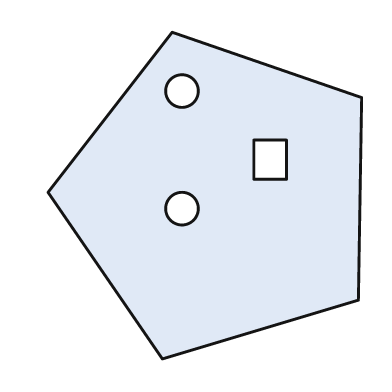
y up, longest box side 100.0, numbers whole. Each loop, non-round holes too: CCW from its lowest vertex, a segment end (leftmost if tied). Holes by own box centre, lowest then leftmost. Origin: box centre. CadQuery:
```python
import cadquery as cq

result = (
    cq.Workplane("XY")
    .moveTo(-13.0, -50.0)
    .lineTo(47.0, -32.0)
    .lineTo(48.0, 30.0)
    .lineTo(-10.0, 50.0)
    .lineTo(-48.0, 1.0)
    .close()
    .moveTo(-7.0, -4.0)
    .circle(5.0)
    .moveTo(15.0, 5.0)
    .lineTo(25.0, 5.0)
    .lineTo(25.0, 17.0)
    .lineTo(15.0, 17.0)
    .close()
    .moveTo(-7.0, 32.0)
    .circle(5.0)
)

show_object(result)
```